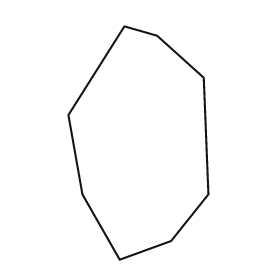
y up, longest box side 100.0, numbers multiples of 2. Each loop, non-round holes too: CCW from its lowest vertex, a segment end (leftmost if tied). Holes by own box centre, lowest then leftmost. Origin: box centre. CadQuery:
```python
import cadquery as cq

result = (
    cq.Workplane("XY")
    .moveTo(-8.0, -50.0)
    .lineTo(14.0, -42.0)
    .lineTo(30.0, -22.0)
    .lineTo(28.0, 28.0)
    .lineTo(8.0, 46.0)
    .lineTo(-6.0, 50.0)
    .lineTo(-30.0, 12.0)
    .lineTo(-24.0, -22.0)
    .close()
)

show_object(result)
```